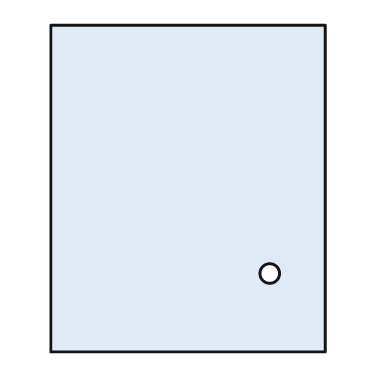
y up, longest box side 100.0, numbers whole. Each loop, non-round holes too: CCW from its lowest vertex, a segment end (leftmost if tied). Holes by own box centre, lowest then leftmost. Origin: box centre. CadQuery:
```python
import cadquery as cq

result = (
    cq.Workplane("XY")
    .moveTo(-42.0, -50.0)
    .lineTo(42.0, -50.0)
    .lineTo(42.0, 50.0)
    .lineTo(-42.0, 50.0)
    .close()
    .moveTo(25.0, -26.0)
    .circle(3.0)
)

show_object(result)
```